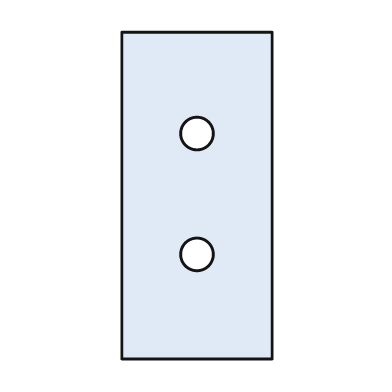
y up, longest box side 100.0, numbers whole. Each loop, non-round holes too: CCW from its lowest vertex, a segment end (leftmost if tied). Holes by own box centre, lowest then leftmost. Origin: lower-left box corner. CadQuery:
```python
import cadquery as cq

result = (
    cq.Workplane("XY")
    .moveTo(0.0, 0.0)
    .lineTo(46.0, 0.0)
    .lineTo(46.0, 100.0)
    .lineTo(0.0, 100.0)
    .close()
    .moveTo(23.0, 32.0)
    .circle(5.0)
    .moveTo(23.0, 69.0)
    .circle(5.0)
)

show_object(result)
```